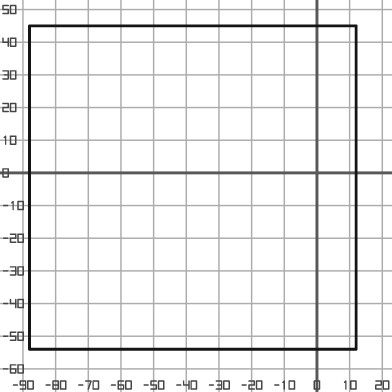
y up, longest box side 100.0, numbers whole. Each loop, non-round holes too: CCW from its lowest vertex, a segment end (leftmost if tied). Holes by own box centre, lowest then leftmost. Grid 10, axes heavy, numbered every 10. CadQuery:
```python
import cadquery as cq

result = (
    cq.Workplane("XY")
    .moveTo(-88.0, -54.0)
    .lineTo(12.0, -54.0)
    .lineTo(12.0, 45.0)
    .lineTo(-88.0, 45.0)
    .close()
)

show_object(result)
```